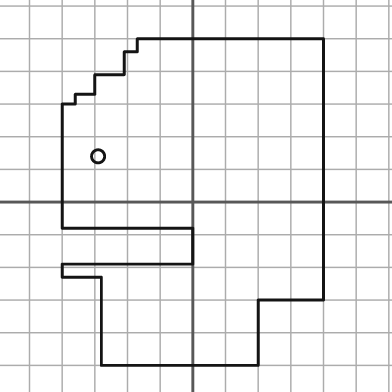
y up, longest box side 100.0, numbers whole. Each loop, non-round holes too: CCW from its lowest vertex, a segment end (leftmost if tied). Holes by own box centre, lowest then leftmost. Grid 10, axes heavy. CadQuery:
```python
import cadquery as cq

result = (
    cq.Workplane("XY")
    .moveTo(-28.0, -50.0)
    .lineTo(20.0, -50.0)
    .lineTo(20.0, -30.0)
    .lineTo(40.0, -30.0)
    .lineTo(40.0, 50.0)
    .lineTo(-17.0, 50.0)
    .lineTo(-17.0, 46.0)
    .lineTo(-21.0, 46.0)
    .lineTo(-21.0, 39.0)
    .lineTo(-30.0, 39.0)
    .lineTo(-30.0, 33.0)
    .lineTo(-36.0, 33.0)
    .lineTo(-36.0, 30.0)
    .lineTo(-40.0, 30.0)
    .lineTo(-40.0, -8.0)
    .lineTo(0.0, -8.0)
    .lineTo(0.0, -19.0)
    .lineTo(-40.0, -19.0)
    .lineTo(-40.0, -23.0)
    .lineTo(-28.0, -23.0)
    .close()
    .moveTo(-29.0, 14.0)
    .circle(2.0)
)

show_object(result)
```